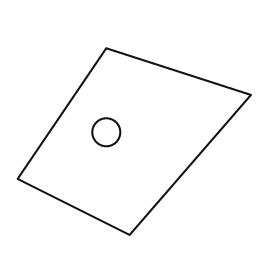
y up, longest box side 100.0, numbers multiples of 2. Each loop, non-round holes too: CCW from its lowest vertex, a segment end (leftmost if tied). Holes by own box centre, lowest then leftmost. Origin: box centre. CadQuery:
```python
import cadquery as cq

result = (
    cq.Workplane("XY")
    .moveTo(-2.0, -40.0)
    .lineTo(50.0, 20.0)
    .lineTo(-12.0, 40.0)
    .lineTo(-50.0, -16.0)
    .close()
    .moveTo(-12.0, 4.0)
    .circle(6.0)
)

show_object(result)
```